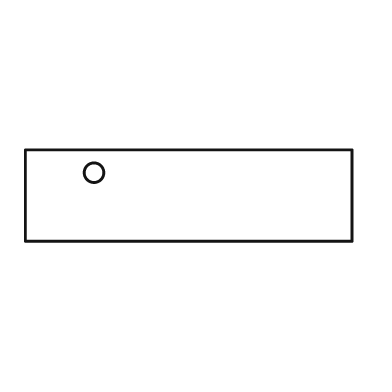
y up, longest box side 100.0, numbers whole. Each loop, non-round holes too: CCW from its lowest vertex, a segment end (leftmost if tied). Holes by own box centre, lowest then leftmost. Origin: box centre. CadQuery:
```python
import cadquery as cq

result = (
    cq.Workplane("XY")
    .moveTo(-50.0, -14.0)
    .lineTo(50.0, -14.0)
    .lineTo(50.0, 14.0)
    .lineTo(-50.0, 14.0)
    .close()
    .moveTo(-29.0, 7.0)
    .circle(3.0)
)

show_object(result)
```